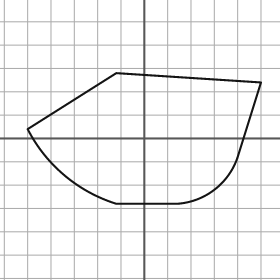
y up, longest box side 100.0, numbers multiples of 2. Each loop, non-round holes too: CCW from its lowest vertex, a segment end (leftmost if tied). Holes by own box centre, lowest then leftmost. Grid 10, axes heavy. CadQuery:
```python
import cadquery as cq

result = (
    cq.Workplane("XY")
    .moveTo(-12.0, -28.0)
    .lineTo(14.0, -28.0)
    .threePointArc((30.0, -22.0), (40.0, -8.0))
    .lineTo(50.0, 24.0)
    .lineTo(-12.0, 28.0)
    .lineTo(-50.0, 4.0)
    .threePointArc((-34.0, -16.0), (-12.0, -28.0))
    .close()
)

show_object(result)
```